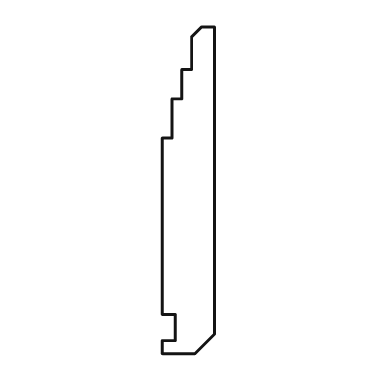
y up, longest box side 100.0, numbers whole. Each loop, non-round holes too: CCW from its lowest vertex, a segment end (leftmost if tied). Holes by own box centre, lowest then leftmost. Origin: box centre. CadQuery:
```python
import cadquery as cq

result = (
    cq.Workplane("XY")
    .moveTo(-8.0, -50.0)
    .lineTo(2.0, -50.0)
    .lineTo(8.0, -44.0)
    .lineTo(8.0, 50.0)
    .lineTo(4.0, 50.0)
    .lineTo(1.0, 47.0)
    .lineTo(1.0, 37.0)
    .lineTo(-2.0, 37.0)
    .lineTo(-2.0, 28.0)
    .lineTo(-5.0, 28.0)
    .lineTo(-5.0, 16.0)
    .lineTo(-8.0, 16.0)
    .lineTo(-8.0, -38.0)
    .lineTo(-4.0, -38.0)
    .lineTo(-4.0, -46.0)
    .lineTo(-8.0, -46.0)
    .close()
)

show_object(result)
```